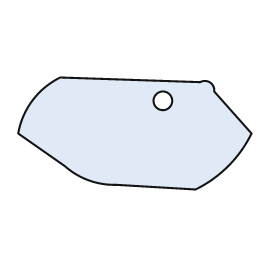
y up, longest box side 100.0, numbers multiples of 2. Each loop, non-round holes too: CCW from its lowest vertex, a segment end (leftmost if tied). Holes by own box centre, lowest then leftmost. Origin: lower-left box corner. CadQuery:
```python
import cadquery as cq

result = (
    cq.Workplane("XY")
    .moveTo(76.0, 0.0)
    .threePointArc((90.0, 10.0), (100.0, 24.0))
    .lineTo(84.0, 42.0)
    .threePointArc((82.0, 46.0), (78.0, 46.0))
    .lineTo(18.0, 48.0)
    .threePointArc((6.0, 38.0), (0.0, 24.0))
    .lineTo(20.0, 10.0)
    .threePointArc((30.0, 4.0), (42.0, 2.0))
    .close()
    .moveTo(62.0, 38.0)
    .circle(4.0)
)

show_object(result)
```